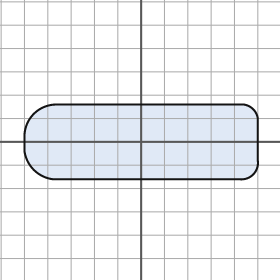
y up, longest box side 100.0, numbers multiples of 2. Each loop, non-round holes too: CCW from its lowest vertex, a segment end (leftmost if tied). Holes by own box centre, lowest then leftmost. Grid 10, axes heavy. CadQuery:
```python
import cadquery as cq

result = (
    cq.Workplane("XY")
    .moveTo(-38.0, -16.0)
    .lineTo(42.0, -16.0)
    .threePointArc((48.0, -14.0), (50.0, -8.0))
    .lineTo(50.0, 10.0)
    .threePointArc((48.0, 14.0), (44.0, 16.0))
    .lineTo(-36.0, 16.0)
    .threePointArc((-46.0, 12.0), (-50.0, 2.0))
    .lineTo(-50.0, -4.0)
    .threePointArc((-46.0, -12.0), (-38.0, -16.0))
    .close()
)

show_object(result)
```